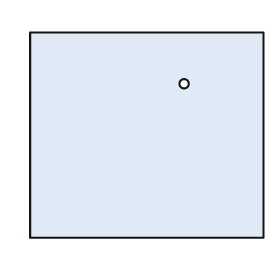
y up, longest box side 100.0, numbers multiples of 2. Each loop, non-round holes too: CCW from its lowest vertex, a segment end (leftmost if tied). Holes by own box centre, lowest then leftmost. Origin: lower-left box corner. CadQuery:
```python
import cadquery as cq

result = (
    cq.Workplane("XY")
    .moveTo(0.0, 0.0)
    .lineTo(100.0, 0.0)
    .lineTo(100.0, 88.0)
    .lineTo(0.0, 88.0)
    .close()
    .moveTo(66.0, 66.0)
    .circle(2.0)
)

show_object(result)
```